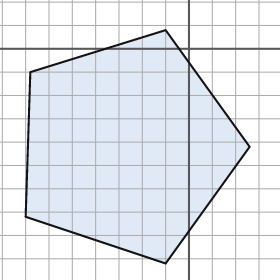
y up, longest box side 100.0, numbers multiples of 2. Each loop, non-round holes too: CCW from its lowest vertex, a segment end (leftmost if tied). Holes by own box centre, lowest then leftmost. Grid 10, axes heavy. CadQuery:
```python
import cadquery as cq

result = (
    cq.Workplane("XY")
    .moveTo(-10.0, -92.0)
    .lineTo(26.0, -42.0)
    .lineTo(-10.0, 8.0)
    .lineTo(-68.0, -10.0)
    .lineTo(-70.0, -72.0)
    .close()
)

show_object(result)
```